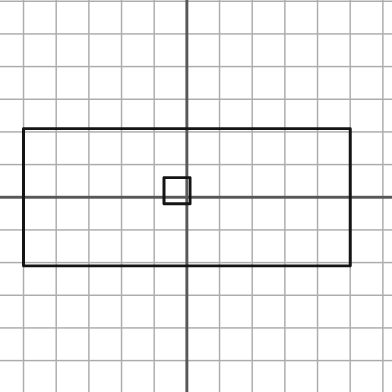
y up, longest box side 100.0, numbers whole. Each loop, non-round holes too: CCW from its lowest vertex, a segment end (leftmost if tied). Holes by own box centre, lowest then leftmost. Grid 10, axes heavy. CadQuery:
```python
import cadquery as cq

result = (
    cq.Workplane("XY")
    .moveTo(-50.0, -21.0)
    .lineTo(50.0, -21.0)
    .lineTo(50.0, 21.0)
    .lineTo(-50.0, 21.0)
    .close()
    .moveTo(-7.0, -2.0)
    .lineTo(1.0, -2.0)
    .lineTo(1.0, 6.0)
    .lineTo(-7.0, 6.0)
    .close()
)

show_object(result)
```